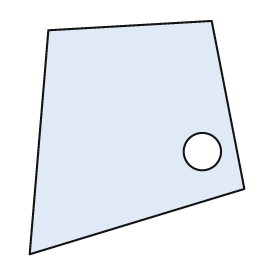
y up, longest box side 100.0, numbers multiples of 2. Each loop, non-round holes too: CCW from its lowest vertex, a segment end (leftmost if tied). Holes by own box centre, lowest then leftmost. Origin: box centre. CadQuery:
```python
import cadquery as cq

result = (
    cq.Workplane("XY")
    .moveTo(-46.0, -50.0)
    .lineTo(46.0, -22.0)
    .lineTo(32.0, 50.0)
    .lineTo(-38.0, 46.0)
    .close()
    .moveTo(28.0, -6.0)
    .circle(8.0)
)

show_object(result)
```